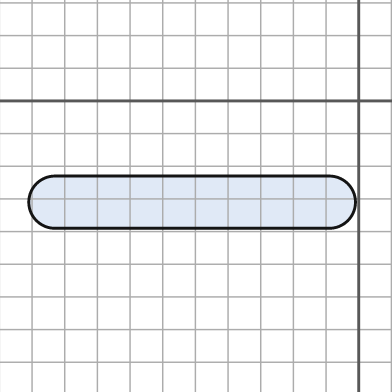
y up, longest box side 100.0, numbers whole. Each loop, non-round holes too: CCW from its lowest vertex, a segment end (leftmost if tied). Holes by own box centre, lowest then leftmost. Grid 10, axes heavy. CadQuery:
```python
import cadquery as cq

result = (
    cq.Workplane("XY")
    .moveTo(-93.0, -39.0)
    .lineTo(-9.0, -39.0)
    .threePointArc((-1.0, -31.0), (-9.0, -23.0))
    .lineTo(-93.0, -23.0)
    .threePointArc((-101.0, -31.0), (-93.0, -39.0))
    .close()
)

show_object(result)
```